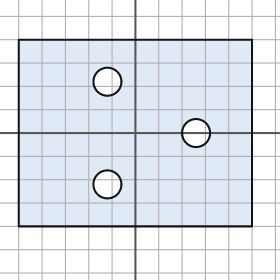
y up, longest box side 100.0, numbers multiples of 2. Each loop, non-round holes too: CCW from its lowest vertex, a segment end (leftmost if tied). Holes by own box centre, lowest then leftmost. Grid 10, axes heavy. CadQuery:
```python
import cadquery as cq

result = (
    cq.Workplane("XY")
    .moveTo(-50.0, -40.0)
    .lineTo(50.0, -40.0)
    .lineTo(50.0, 40.0)
    .lineTo(-50.0, 40.0)
    .close()
    .moveTo(-12.0, -22.0)
    .circle(6.0)
    .moveTo(26.0, 0.0)
    .circle(6.0)
    .moveTo(-12.0, 22.0)
    .circle(6.0)
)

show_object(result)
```